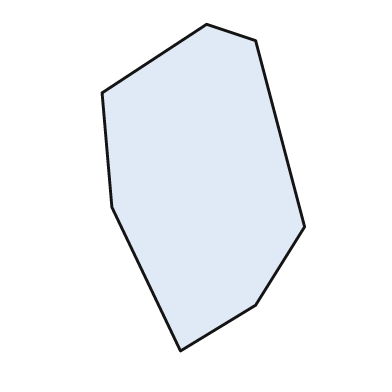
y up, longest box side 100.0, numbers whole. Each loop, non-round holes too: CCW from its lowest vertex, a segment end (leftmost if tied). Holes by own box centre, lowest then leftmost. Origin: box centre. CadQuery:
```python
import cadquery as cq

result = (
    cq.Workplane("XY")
    .moveTo(-7.0, -50.0)
    .lineTo(16.0, -36.0)
    .lineTo(31.0, -12.0)
    .lineTo(16.0, 45.0)
    .lineTo(1.0, 50.0)
    .lineTo(-31.0, 29.0)
    .lineTo(-28.0, -6.0)
    .close()
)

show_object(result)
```